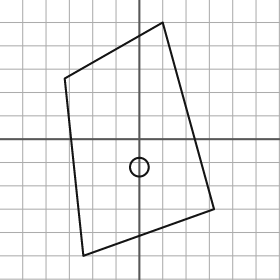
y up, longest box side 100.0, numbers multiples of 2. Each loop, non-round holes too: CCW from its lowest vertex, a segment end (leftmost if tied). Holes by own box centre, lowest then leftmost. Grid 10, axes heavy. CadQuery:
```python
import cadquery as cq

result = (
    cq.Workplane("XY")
    .moveTo(-24.0, -50.0)
    .lineTo(32.0, -30.0)
    .lineTo(10.0, 50.0)
    .lineTo(-32.0, 26.0)
    .close()
    .moveTo(0.0, -12.0)
    .circle(4.0)
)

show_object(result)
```